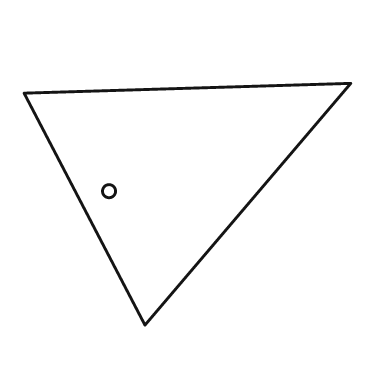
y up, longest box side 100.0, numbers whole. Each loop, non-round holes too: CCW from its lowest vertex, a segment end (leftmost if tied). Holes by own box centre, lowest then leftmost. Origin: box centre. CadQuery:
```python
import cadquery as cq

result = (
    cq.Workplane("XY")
    .moveTo(-13.0, -37.0)
    .lineTo(50.0, 37.0)
    .lineTo(-50.0, 34.0)
    .close()
    .moveTo(-24.0, 4.0)
    .circle(2.0)
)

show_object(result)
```